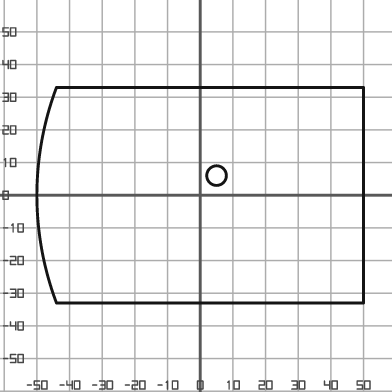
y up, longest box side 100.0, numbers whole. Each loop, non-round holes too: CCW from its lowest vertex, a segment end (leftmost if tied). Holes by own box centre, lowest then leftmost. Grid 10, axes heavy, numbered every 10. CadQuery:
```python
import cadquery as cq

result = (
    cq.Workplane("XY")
    .moveTo(-44.0, -33.0)
    .lineTo(50.0, -33.0)
    .lineTo(50.0, 33.0)
    .lineTo(-44.0, 33.0)
    .threePointArc((-50.0, 0.0), (-44.0, -33.0))
    .close()
    .moveTo(5.0, 6.0)
    .circle(3.0)
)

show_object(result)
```